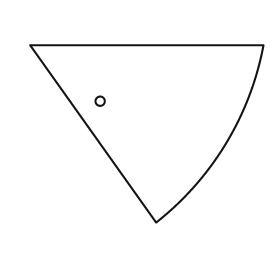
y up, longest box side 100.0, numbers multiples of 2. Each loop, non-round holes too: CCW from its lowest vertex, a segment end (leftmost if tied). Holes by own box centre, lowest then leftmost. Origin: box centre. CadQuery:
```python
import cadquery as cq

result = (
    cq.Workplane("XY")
    .moveTo(4.0, -38.0)
    .threePointArc((34.0, -4.0), (50.0, 38.0))
    .lineTo(-50.0, 38.0)
    .close()
    .moveTo(-20.0, 14.0)
    .circle(2.0)
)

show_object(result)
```